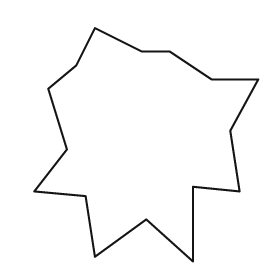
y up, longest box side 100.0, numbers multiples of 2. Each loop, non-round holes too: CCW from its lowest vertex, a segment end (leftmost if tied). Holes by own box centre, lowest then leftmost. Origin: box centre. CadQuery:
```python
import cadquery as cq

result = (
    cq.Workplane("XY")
    .moveTo(20.0, -50.0)
    .lineTo(20.0, -18.0)
    .lineTo(40.0, -20.0)
    .lineTo(36.0, 6.0)
    .lineTo(48.0, 28.0)
    .lineTo(28.0, 28.0)
    .lineTo(10.0, 40.0)
    .lineTo(-2.0, 40.0)
    .lineTo(-22.0, 50.0)
    .lineTo(-30.0, 34.0)
    .lineTo(-42.0, 24.0)
    .lineTo(-34.0, -2.0)
    .lineTo(-48.0, -20.0)
    .lineTo(-26.0, -22.0)
    .lineTo(-22.0, -48.0)
    .lineTo(0.0, -32.0)
    .close()
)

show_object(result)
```